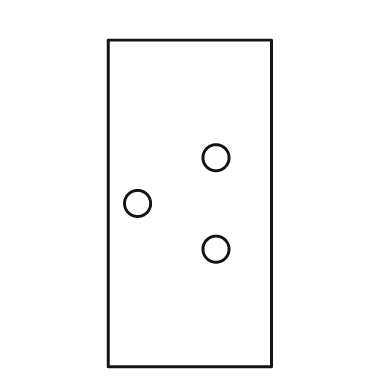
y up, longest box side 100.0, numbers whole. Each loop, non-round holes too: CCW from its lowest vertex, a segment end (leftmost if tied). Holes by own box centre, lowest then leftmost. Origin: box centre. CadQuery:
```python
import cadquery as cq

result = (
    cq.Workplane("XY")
    .moveTo(-25.0, -50.0)
    .lineTo(25.0, -50.0)
    .lineTo(25.0, 50.0)
    .lineTo(-25.0, 50.0)
    .close()
    .moveTo(8.0, -14.0)
    .circle(4.0)
    .moveTo(-16.0, 0.0)
    .circle(4.0)
    .moveTo(8.0, 14.0)
    .circle(4.0)
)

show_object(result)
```